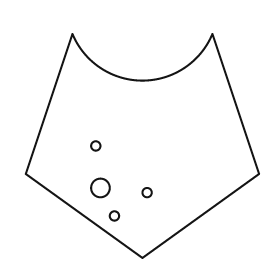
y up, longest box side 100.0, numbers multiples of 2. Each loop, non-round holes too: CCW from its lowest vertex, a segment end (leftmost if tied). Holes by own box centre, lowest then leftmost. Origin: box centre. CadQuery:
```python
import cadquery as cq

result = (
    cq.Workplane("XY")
    .moveTo(0.0, -48.0)
    .lineTo(50.0, -12.0)
    .lineTo(30.0, 48.0)
    .threePointArc((0.0, 28.0), (-30.0, 48.0))
    .lineTo(-50.0, -12.0)
    .close()
    .moveTo(-12.0, -30.0)
    .circle(2.0)
    .moveTo(2.0, -20.0)
    .circle(2.0)
    .moveTo(-18.0, -18.0)
    .circle(4.0)
    .moveTo(-20.0, 0.0)
    .circle(2.0)
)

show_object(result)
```